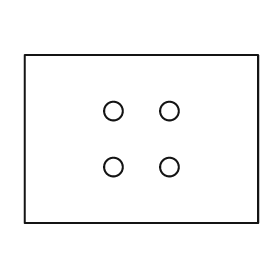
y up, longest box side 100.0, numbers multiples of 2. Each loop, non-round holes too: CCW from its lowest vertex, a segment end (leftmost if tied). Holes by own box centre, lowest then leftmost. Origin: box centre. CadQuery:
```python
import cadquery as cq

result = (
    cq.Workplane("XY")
    .moveTo(-50.0, -36.0)
    .lineTo(50.0, -36.0)
    .lineTo(50.0, 36.0)
    .lineTo(-50.0, 36.0)
    .close()
    .moveTo(-12.0, -12.0)
    .circle(4.0)
    .moveTo(12.0, -12.0)
    .circle(4.0)
    .moveTo(-12.0, 12.0)
    .circle(4.0)
    .moveTo(12.0, 12.0)
    .circle(4.0)
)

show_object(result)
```